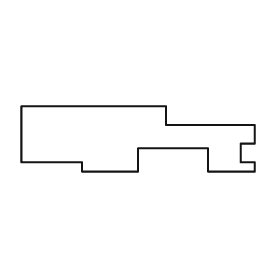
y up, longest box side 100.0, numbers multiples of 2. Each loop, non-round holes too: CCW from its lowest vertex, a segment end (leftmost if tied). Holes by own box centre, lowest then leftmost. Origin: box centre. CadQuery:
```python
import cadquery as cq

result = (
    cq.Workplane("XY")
    .moveTo(-24.0, -14.0)
    .lineTo(0.0, -14.0)
    .lineTo(0.0, -4.0)
    .lineTo(30.0, -4.0)
    .lineTo(30.0, -14.0)
    .lineTo(50.0, -14.0)
    .lineTo(50.0, -10.0)
    .lineTo(44.0, -10.0)
    .lineTo(44.0, -2.0)
    .lineTo(50.0, -2.0)
    .lineTo(50.0, 6.0)
    .lineTo(12.0, 6.0)
    .lineTo(12.0, 14.0)
    .lineTo(-50.0, 14.0)
    .lineTo(-50.0, -10.0)
    .lineTo(-24.0, -10.0)
    .close()
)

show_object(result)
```